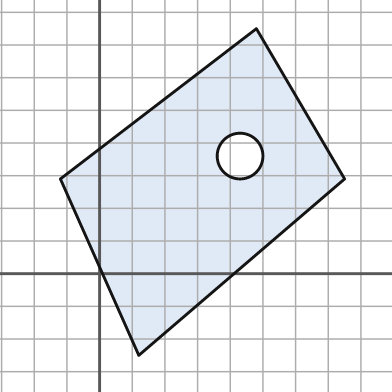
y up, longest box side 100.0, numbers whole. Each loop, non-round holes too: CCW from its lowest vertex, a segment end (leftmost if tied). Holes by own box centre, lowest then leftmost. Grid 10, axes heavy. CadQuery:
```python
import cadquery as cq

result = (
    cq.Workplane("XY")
    .moveTo(12.0, -25.0)
    .lineTo(75.0, 29.0)
    .lineTo(48.0, 75.0)
    .lineTo(-12.0, 29.0)
    .close()
    .moveTo(43.0, 36.0)
    .circle(7.0)
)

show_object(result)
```